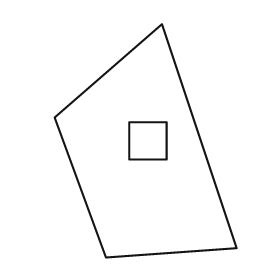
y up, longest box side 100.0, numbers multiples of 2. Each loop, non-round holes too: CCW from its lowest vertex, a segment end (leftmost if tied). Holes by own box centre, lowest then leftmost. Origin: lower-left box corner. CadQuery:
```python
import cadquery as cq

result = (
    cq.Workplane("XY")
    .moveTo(22.0, 0.0)
    .lineTo(78.0, 4.0)
    .lineTo(46.0, 100.0)
    .lineTo(0.0, 60.0)
    .close()
    .moveTo(32.0, 42.0)
    .lineTo(48.0, 42.0)
    .lineTo(48.0, 58.0)
    .lineTo(32.0, 58.0)
    .close()
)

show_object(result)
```